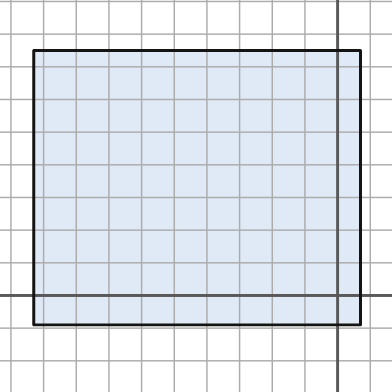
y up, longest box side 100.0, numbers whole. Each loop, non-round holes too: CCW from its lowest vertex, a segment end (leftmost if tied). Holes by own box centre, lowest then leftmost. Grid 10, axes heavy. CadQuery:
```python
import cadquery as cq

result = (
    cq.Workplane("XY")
    .moveTo(-93.0, -9.0)
    .lineTo(7.0, -9.0)
    .lineTo(7.0, 75.0)
    .lineTo(-93.0, 75.0)
    .close()
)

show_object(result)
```